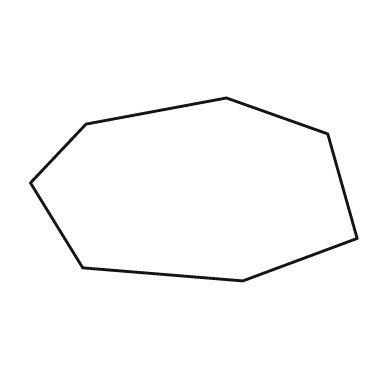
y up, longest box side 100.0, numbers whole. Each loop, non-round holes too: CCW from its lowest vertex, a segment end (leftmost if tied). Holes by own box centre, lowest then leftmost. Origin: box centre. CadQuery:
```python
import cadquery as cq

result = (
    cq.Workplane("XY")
    .moveTo(15.0, -28.0)
    .lineTo(50.0, -15.0)
    .lineTo(41.0, 17.0)
    .lineTo(10.0, 28.0)
    .lineTo(-33.0, 20.0)
    .lineTo(-50.0, 2.0)
    .lineTo(-34.0, -24.0)
    .close()
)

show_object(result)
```